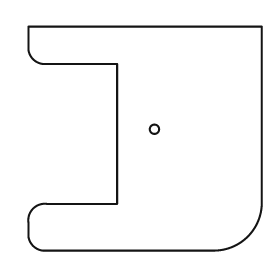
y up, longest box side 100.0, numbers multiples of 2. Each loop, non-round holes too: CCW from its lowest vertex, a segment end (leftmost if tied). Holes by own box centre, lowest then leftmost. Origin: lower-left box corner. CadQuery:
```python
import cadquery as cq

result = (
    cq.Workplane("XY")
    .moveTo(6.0, 0.0)
    .lineTo(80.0, 0.0)
    .threePointArc((94.0, 6.0), (100.0, 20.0))
    .lineTo(100.0, 96.0)
    .lineTo(0.0, 96.0)
    .lineTo(0.0, 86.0)
    .threePointArc((2.0, 82.0), (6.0, 80.0))
    .lineTo(38.0, 80.0)
    .lineTo(38.0, 20.0)
    .lineTo(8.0, 20.0)
    .threePointArc((2.0, 18.0), (0.0, 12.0))
    .lineTo(0.0, 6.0)
    .threePointArc((2.0, 2.0), (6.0, 0.0))
    .close()
    .moveTo(54.0, 52.0)
    .circle(2.0)
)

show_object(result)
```